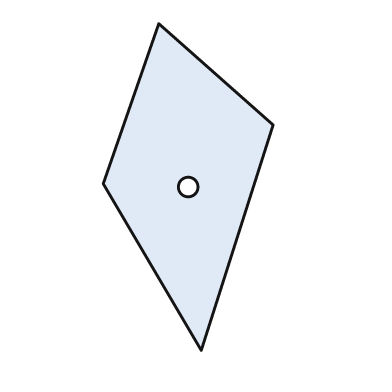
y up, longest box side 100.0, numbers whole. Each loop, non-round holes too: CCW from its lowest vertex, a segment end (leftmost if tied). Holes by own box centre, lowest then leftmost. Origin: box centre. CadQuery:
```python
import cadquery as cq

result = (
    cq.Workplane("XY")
    .moveTo(4.0, -50.0)
    .lineTo(26.0, 19.0)
    .lineTo(-9.0, 50.0)
    .lineTo(-26.0, 1.0)
    .close()
    .moveTo(0.0, 0.0)
    .circle(3.0)
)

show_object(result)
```